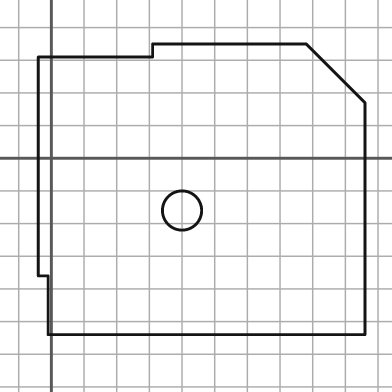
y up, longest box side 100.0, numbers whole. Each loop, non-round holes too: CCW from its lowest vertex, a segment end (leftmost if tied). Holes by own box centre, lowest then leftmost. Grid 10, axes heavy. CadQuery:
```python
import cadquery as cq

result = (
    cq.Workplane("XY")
    .moveTo(-1.0, -54.0)
    .lineTo(96.0, -54.0)
    .lineTo(96.0, 17.0)
    .lineTo(78.0, 35.0)
    .lineTo(31.0, 35.0)
    .lineTo(31.0, 31.0)
    .lineTo(-4.0, 31.0)
    .lineTo(-4.0, -36.0)
    .lineTo(-1.0, -36.0)
    .close()
    .moveTo(40.0, -16.0)
    .circle(6.0)
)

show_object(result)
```